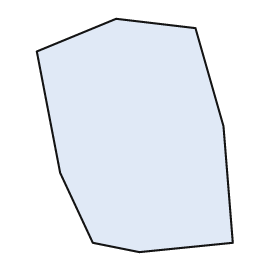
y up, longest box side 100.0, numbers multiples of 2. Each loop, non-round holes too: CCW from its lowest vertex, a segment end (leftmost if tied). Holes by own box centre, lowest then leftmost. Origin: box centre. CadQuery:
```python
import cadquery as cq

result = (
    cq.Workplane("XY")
    .moveTo(2.0, -50.0)
    .lineTo(42.0, -46.0)
    .lineTo(38.0, 4.0)
    .lineTo(26.0, 46.0)
    .lineTo(-8.0, 50.0)
    .lineTo(-42.0, 36.0)
    .lineTo(-32.0, -16.0)
    .lineTo(-18.0, -46.0)
    .close()
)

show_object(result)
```